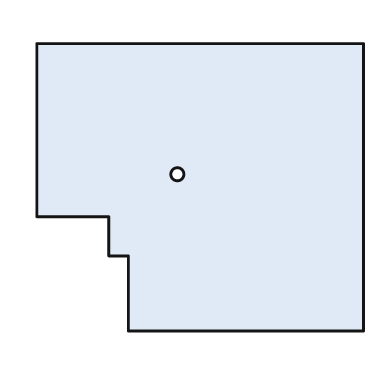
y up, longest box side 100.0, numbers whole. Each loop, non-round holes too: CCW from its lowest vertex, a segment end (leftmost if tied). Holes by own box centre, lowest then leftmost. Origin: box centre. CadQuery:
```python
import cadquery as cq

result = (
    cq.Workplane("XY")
    .moveTo(-22.0, -44.0)
    .lineTo(50.0, -44.0)
    .lineTo(50.0, 44.0)
    .lineTo(-50.0, 44.0)
    .lineTo(-50.0, -9.0)
    .lineTo(-28.0, -9.0)
    .lineTo(-28.0, -21.0)
    .lineTo(-22.0, -21.0)
    .close()
    .moveTo(-7.0, 4.0)
    .circle(2.0)
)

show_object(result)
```